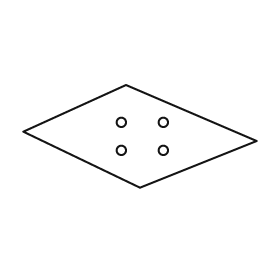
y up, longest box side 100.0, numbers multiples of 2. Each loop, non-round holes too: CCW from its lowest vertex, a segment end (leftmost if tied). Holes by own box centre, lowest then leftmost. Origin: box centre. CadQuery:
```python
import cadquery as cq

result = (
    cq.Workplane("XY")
    .moveTo(0.0, -22.0)
    .lineTo(50.0, -2.0)
    .lineTo(-6.0, 22.0)
    .lineTo(-50.0, 2.0)
    .close()
    .moveTo(-8.0, -6.0)
    .circle(2.0)
    .moveTo(10.0, -6.0)
    .circle(2.0)
    .moveTo(-8.0, 6.0)
    .circle(2.0)
    .moveTo(10.0, 6.0)
    .circle(2.0)
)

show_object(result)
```